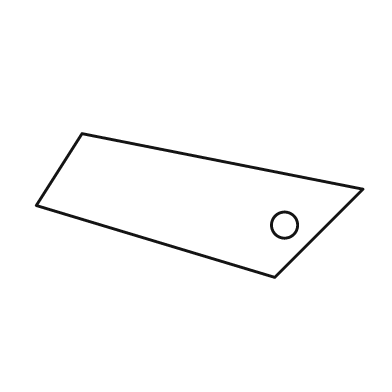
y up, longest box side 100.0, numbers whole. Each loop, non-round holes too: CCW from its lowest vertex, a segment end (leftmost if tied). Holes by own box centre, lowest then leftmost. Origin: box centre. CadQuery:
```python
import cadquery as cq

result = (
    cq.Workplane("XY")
    .moveTo(23.0, -22.0)
    .lineTo(50.0, 5.0)
    .lineTo(-36.0, 22.0)
    .lineTo(-50.0, 0.0)
    .close()
    .moveTo(26.0, -6.0)
    .circle(4.0)
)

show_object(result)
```